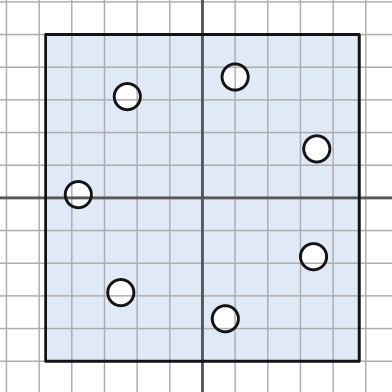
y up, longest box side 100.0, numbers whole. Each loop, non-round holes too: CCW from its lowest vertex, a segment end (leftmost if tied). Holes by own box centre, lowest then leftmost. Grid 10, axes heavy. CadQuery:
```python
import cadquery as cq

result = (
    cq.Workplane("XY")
    .moveTo(-48.0, -50.0)
    .lineTo(48.0, -50.0)
    .lineTo(48.0, 50.0)
    .lineTo(-48.0, 50.0)
    .close()
    .moveTo(7.0, -37.0)
    .circle(4.0)
    .moveTo(-25.0, -29.0)
    .circle(4.0)
    .moveTo(34.0, -18.0)
    .circle(4.0)
    .moveTo(-38.0, 1.0)
    .circle(4.0)
    .moveTo(35.0, 15.0)
    .circle(4.0)
    .moveTo(-23.0, 31.0)
    .circle(4.0)
    .moveTo(10.0, 37.0)
    .circle(4.0)
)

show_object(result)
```